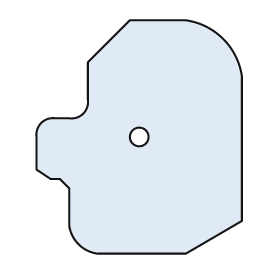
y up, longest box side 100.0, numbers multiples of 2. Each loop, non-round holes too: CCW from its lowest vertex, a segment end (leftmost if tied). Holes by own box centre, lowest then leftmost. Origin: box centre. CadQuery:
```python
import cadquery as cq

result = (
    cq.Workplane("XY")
    .moveTo(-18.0, -50.0)
    .lineTo(20.0, -50.0)
    .lineTo(44.0, -36.0)
    .lineTo(44.0, 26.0)
    .threePointArc((36.0, 42.0), (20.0, 50.0))
    .lineTo(-4.0, 50.0)
    .lineTo(-22.0, 32.0)
    .lineTo(-22.0, 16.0)
    .threePointArc((-24.0, 10.0), (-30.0, 8.0))
    .lineTo(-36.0, 8.0)
    .threePointArc((-42.0, 6.0), (-44.0, 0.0))
    .lineTo(-44.0, -14.0)
    .lineTo(-38.0, -18.0)
    .lineTo(-34.0, -18.0)
    .lineTo(-30.0, -22.0)
    .lineTo(-30.0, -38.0)
    .threePointArc((-26.0, -46.0), (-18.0, -50.0))
    .close()
    .moveTo(0.0, 0.0)
    .circle(4.0)
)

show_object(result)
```